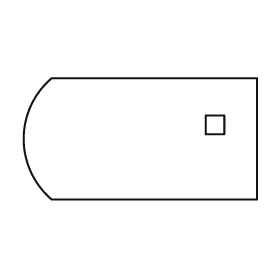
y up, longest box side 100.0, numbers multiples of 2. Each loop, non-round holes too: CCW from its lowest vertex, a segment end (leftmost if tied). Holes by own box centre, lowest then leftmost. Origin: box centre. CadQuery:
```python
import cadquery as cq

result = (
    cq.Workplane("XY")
    .moveTo(-38.0, -26.0)
    .lineTo(50.0, -26.0)
    .lineTo(50.0, 26.0)
    .lineTo(-38.0, 26.0)
    .threePointArc((-50.0, 0.0), (-38.0, -26.0))
    .close()
    .moveTo(28.0, 2.0)
    .lineTo(36.0, 2.0)
    .lineTo(36.0, 10.0)
    .lineTo(28.0, 10.0)
    .close()
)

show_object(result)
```